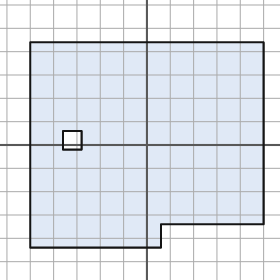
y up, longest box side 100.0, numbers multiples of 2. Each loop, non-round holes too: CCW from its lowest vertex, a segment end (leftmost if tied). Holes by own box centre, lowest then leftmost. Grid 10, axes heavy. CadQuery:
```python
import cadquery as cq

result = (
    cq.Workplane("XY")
    .moveTo(-50.0, -44.0)
    .lineTo(6.0, -44.0)
    .lineTo(6.0, -34.0)
    .lineTo(50.0, -34.0)
    .lineTo(50.0, 44.0)
    .lineTo(-50.0, 44.0)
    .close()
    .moveTo(-36.0, -2.0)
    .lineTo(-28.0, -2.0)
    .lineTo(-28.0, 6.0)
    .lineTo(-36.0, 6.0)
    .close()
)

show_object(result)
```